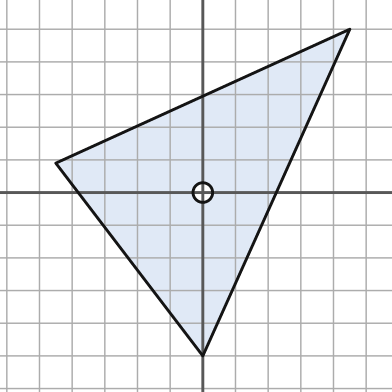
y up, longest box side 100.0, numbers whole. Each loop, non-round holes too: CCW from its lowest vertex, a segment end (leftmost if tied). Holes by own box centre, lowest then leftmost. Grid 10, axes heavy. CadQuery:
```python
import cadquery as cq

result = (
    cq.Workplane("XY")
    .moveTo(0.0, -50.0)
    .lineTo(45.0, 50.0)
    .lineTo(-45.0, 9.0)
    .close()
    .moveTo(0.0, 0.0)
    .circle(3.0)
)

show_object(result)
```